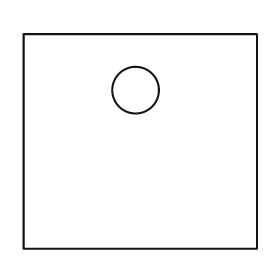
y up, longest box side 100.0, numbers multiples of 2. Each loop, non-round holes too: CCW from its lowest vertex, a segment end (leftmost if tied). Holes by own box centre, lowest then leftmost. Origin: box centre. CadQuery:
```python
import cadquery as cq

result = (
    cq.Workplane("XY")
    .moveTo(-50.0, -46.0)
    .lineTo(50.0, -46.0)
    .lineTo(50.0, 46.0)
    .lineTo(-50.0, 46.0)
    .close()
    .moveTo(-2.0, 22.0)
    .circle(10.0)
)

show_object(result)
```